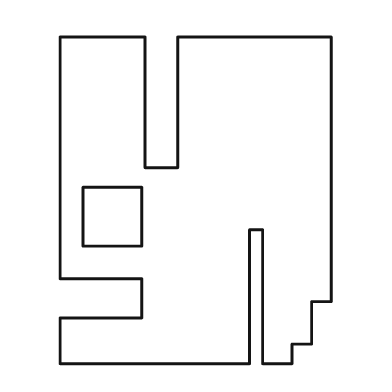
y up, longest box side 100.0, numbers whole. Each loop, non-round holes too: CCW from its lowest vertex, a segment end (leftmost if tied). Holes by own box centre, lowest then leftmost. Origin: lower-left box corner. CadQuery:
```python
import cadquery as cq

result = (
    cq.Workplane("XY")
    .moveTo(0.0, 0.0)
    .lineTo(58.0, 0.0)
    .lineTo(58.0, 41.0)
    .lineTo(62.0, 41.0)
    .lineTo(62.0, 0.0)
    .lineTo(71.0, 0.0)
    .lineTo(71.0, 6.0)
    .lineTo(77.0, 6.0)
    .lineTo(77.0, 19.0)
    .lineTo(83.0, 19.0)
    .lineTo(83.0, 100.0)
    .lineTo(36.0, 100.0)
    .lineTo(36.0, 60.0)
    .lineTo(26.0, 60.0)
    .lineTo(26.0, 100.0)
    .lineTo(0.0, 100.0)
    .lineTo(0.0, 26.0)
    .lineTo(25.0, 26.0)
    .lineTo(25.0, 14.0)
    .lineTo(0.0, 14.0)
    .close()
    .moveTo(7.0, 36.0)
    .lineTo(25.0, 36.0)
    .lineTo(25.0, 54.0)
    .lineTo(7.0, 54.0)
    .close()
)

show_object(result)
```